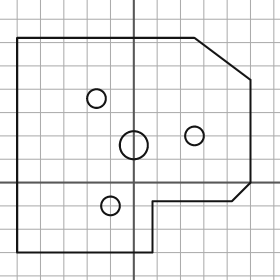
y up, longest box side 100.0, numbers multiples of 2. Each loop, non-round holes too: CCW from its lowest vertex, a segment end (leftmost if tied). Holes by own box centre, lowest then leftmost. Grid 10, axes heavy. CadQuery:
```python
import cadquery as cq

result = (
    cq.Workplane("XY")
    .moveTo(-50.0, -30.0)
    .lineTo(8.0, -30.0)
    .lineTo(8.0, -8.0)
    .lineTo(42.0, -8.0)
    .lineTo(50.0, 0.0)
    .lineTo(50.0, 44.0)
    .lineTo(26.0, 62.0)
    .lineTo(-50.0, 62.0)
    .close()
    .moveTo(-10.0, -10.0)
    .circle(4.0)
    .moveTo(0.0, 16.0)
    .circle(6.0)
    .moveTo(26.0, 20.0)
    .circle(4.0)
    .moveTo(-16.0, 36.0)
    .circle(4.0)
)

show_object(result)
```